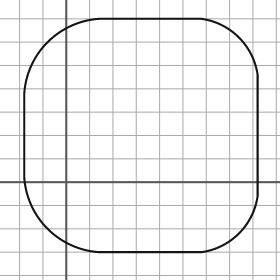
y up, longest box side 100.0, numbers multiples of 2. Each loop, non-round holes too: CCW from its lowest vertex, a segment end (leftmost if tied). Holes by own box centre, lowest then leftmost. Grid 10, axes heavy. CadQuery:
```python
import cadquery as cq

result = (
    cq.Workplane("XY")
    .moveTo(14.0, -30.0)
    .lineTo(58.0, -30.0)
    .threePointArc((74.0, -22.0), (82.0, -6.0))
    .lineTo(82.0, 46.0)
    .threePointArc((74.0, 62.0), (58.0, 70.0))
    .lineTo(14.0, 70.0)
    .threePointArc((-8.0, 60.0), (-18.0, 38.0))
    .lineTo(-18.0, 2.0)
    .threePointArc((-8.0, -20.0), (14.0, -30.0))
    .close()
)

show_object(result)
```